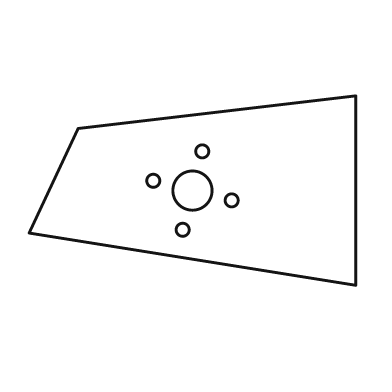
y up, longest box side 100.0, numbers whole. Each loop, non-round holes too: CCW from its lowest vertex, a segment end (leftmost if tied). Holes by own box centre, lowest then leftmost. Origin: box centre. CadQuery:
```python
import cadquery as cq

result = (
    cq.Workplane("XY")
    .moveTo(50.0, -29.0)
    .lineTo(50.0, 29.0)
    .lineTo(-35.0, 19.0)
    .lineTo(-50.0, -13.0)
    .close()
    .moveTo(-3.0, -12.0)
    .circle(2.0)
    .moveTo(12.0, -3.0)
    .circle(2.0)
    .moveTo(0.0, 0.0)
    .circle(6.0)
    .moveTo(-12.0, 3.0)
    .circle(2.0)
    .moveTo(3.0, 12.0)
    .circle(2.0)
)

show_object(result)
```